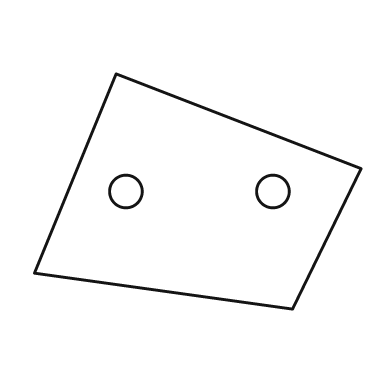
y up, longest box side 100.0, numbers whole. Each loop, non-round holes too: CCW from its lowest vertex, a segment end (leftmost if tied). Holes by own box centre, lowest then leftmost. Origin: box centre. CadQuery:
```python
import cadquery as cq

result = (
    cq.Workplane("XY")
    .moveTo(29.0, -36.0)
    .lineTo(50.0, 7.0)
    .lineTo(-25.0, 36.0)
    .lineTo(-50.0, -25.0)
    .close()
    .moveTo(-22.0, 0.0)
    .circle(5.0)
    .moveTo(23.0, 0.0)
    .circle(5.0)
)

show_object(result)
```